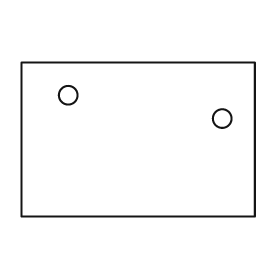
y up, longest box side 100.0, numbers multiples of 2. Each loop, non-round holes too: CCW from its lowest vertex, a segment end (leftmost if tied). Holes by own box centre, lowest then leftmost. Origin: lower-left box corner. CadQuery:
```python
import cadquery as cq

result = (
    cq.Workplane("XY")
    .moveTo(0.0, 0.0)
    .lineTo(100.0, 0.0)
    .lineTo(100.0, 66.0)
    .lineTo(0.0, 66.0)
    .close()
    .moveTo(86.0, 42.0)
    .circle(4.0)
    .moveTo(20.0, 52.0)
    .circle(4.0)
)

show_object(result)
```